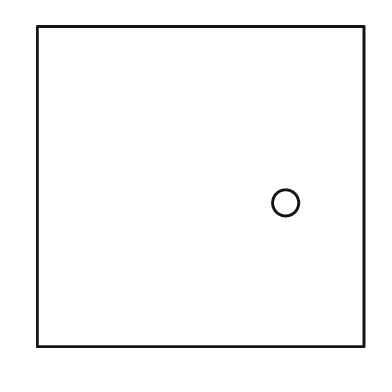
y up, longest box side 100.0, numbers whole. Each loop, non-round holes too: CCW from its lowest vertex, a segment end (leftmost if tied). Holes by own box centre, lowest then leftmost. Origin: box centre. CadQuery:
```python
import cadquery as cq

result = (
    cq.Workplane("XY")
    .moveTo(-50.0, -49.0)
    .lineTo(50.0, -49.0)
    .lineTo(50.0, 49.0)
    .lineTo(-50.0, 49.0)
    .close()
    .moveTo(26.0, -5.0)
    .circle(4.0)
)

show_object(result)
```